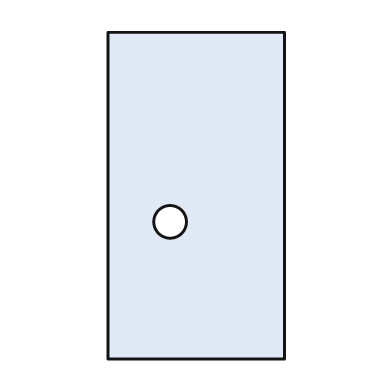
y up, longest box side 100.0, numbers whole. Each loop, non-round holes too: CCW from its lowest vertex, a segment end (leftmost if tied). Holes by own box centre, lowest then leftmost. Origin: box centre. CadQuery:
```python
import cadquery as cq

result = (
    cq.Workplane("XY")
    .moveTo(-27.0, -50.0)
    .lineTo(27.0, -50.0)
    .lineTo(27.0, 50.0)
    .lineTo(-27.0, 50.0)
    .close()
    .moveTo(-8.0, -8.0)
    .circle(5.0)
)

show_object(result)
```